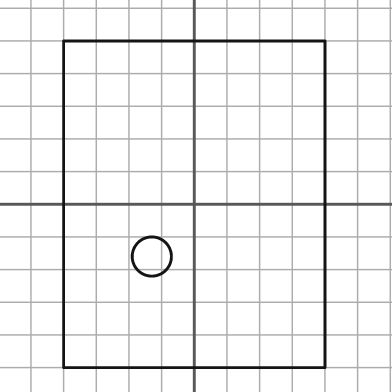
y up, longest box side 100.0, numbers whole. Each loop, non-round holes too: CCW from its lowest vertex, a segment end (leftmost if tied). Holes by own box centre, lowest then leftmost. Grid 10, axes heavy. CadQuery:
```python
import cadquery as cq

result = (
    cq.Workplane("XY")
    .moveTo(-40.0, -50.0)
    .lineTo(40.0, -50.0)
    .lineTo(40.0, 50.0)
    .lineTo(-40.0, 50.0)
    .close()
    .moveTo(-13.0, -16.0)
    .circle(6.0)
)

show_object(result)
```